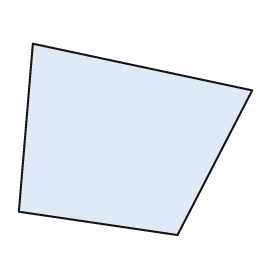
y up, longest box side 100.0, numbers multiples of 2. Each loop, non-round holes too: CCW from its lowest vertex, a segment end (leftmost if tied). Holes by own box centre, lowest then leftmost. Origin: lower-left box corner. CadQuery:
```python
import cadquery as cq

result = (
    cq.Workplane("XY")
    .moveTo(68.0, 0.0)
    .lineTo(100.0, 62.0)
    .lineTo(6.0, 82.0)
    .lineTo(0.0, 10.0)
    .close()
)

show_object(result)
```